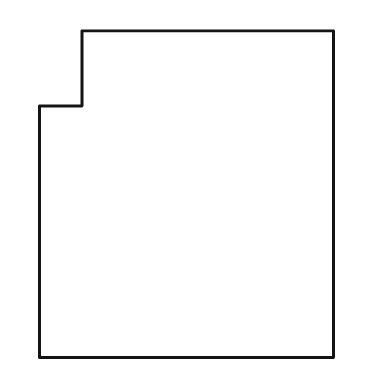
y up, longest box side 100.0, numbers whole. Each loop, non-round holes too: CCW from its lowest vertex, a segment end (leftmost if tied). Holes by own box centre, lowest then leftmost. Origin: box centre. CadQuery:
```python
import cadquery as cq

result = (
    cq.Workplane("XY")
    .moveTo(-45.0, -50.0)
    .lineTo(45.0, -50.0)
    .lineTo(45.0, 50.0)
    .lineTo(-32.0, 50.0)
    .lineTo(-32.0, 27.0)
    .lineTo(-45.0, 27.0)
    .close()
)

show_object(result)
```